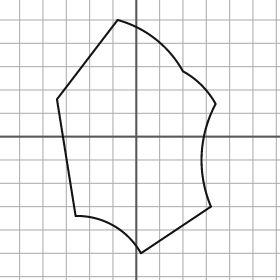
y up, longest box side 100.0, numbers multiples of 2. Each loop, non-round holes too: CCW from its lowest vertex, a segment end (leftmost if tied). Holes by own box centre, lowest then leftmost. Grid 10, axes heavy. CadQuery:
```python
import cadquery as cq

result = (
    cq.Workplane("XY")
    .moveTo(2.0, -50.0)
    .lineTo(32.0, -30.0)
    .threePointArc((28.0, -8.0), (34.0, 14.0))
    .threePointArc((28.0, 22.0), (20.0, 28.0))
    .threePointArc((8.0, 42.0), (-8.0, 50.0))
    .lineTo(-34.0, 16.0)
    .lineTo(-26.0, -34.0)
    .threePointArc((-10.0, -38.0), (2.0, -50.0))
    .close()
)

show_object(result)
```